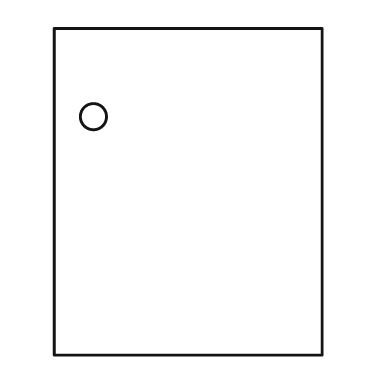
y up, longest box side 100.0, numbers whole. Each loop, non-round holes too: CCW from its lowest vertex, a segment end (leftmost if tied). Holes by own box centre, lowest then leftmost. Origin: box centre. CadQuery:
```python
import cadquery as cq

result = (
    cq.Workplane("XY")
    .moveTo(-41.0, -50.0)
    .lineTo(41.0, -50.0)
    .lineTo(41.0, 50.0)
    .lineTo(-41.0, 50.0)
    .close()
    .moveTo(-29.0, 23.0)
    .circle(4.0)
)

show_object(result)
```